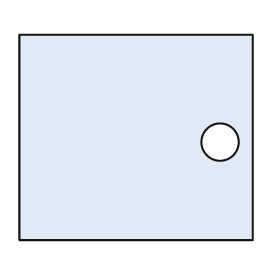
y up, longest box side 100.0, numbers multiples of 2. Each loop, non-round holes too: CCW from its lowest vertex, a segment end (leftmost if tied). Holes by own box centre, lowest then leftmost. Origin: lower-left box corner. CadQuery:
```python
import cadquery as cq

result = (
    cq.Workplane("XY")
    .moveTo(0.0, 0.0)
    .lineTo(100.0, 0.0)
    .lineTo(100.0, 88.0)
    .lineTo(0.0, 88.0)
    .close()
    .moveTo(86.0, 42.0)
    .circle(8.0)
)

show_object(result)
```